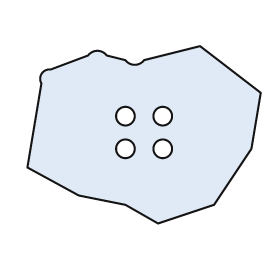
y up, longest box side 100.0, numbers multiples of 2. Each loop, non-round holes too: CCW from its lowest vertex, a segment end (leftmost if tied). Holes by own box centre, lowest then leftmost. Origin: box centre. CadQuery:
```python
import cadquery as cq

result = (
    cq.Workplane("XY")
    .moveTo(6.0, -38.0)
    .lineTo(30.0, -30.0)
    .lineTo(46.0, -6.0)
    .lineTo(50.0, 18.0)
    .lineTo(24.0, 38.0)
    .lineTo(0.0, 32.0)
    .threePointArc((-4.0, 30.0), (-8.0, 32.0))
    .lineTo(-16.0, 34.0)
    .threePointArc((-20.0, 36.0), (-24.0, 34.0))
    .lineTo(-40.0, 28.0)
    .threePointArc((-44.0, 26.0), (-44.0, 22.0))
    .lineTo(-50.0, -14.0)
    .lineTo(-28.0, -26.0)
    .lineTo(-8.0, -30.0)
    .close()
    .moveTo(-8.0, -6.0)
    .circle(4.0)
    .moveTo(8.0, -6.0)
    .circle(4.0)
    .moveTo(-8.0, 8.0)
    .circle(4.0)
    .moveTo(8.0, 8.0)
    .circle(4.0)
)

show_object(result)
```